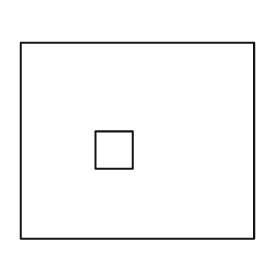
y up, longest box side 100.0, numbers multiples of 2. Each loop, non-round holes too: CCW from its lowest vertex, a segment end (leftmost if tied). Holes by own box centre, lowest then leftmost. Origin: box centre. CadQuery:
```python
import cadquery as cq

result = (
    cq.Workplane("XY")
    .moveTo(-50.0, -42.0)
    .lineTo(50.0, -42.0)
    .lineTo(50.0, 42.0)
    .lineTo(-50.0, 42.0)
    .close()
    .moveTo(-18.0, -12.0)
    .lineTo(-2.0, -12.0)
    .lineTo(-2.0, 4.0)
    .lineTo(-18.0, 4.0)
    .close()
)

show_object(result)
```